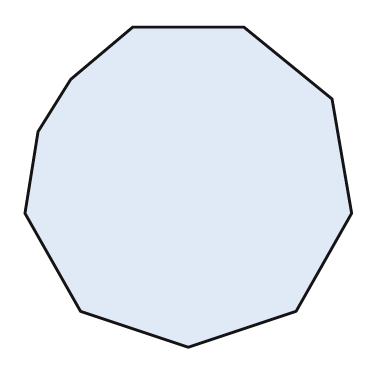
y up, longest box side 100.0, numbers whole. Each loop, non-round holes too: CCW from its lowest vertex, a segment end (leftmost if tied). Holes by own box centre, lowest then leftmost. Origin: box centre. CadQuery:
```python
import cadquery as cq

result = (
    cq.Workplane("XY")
    .moveTo(0.0, -49.0)
    .lineTo(33.0, -38.0)
    .lineTo(50.0, -8.0)
    .lineTo(44.0, 27.0)
    .lineTo(17.0, 49.0)
    .lineTo(-17.0, 49.0)
    .lineTo(-36.0, 33.0)
    .lineTo(-46.0, 17.0)
    .lineTo(-50.0, -8.0)
    .lineTo(-33.0, -38.0)
    .close()
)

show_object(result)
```